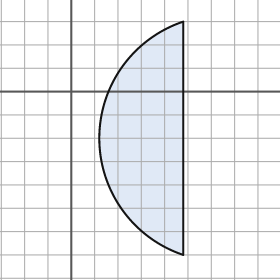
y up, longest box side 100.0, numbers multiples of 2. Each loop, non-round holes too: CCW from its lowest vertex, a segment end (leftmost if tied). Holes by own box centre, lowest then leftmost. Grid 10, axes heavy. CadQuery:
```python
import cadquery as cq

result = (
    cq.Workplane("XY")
    .moveTo(48.0, -70.0)
    .lineTo(48.0, 30.0)
    .threePointArc((12.0, -20.0), (48.0, -70.0))
    .close()
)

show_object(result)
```